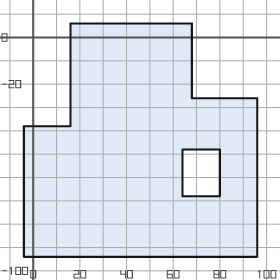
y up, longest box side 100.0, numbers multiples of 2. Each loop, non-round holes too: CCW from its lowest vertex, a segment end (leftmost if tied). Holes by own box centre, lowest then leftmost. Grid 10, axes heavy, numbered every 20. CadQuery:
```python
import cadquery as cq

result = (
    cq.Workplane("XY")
    .moveTo(-4.0, -94.0)
    .lineTo(96.0, -94.0)
    .lineTo(96.0, -26.0)
    .lineTo(68.0, -26.0)
    .lineTo(68.0, 6.0)
    .lineTo(16.0, 6.0)
    .lineTo(16.0, -38.0)
    .lineTo(-4.0, -38.0)
    .close()
    .moveTo(64.0, -68.0)
    .lineTo(80.0, -68.0)
    .lineTo(80.0, -48.0)
    .lineTo(64.0, -48.0)
    .close()
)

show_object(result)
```